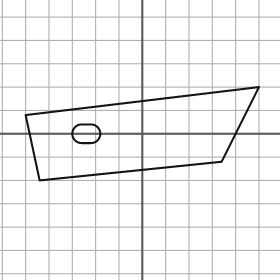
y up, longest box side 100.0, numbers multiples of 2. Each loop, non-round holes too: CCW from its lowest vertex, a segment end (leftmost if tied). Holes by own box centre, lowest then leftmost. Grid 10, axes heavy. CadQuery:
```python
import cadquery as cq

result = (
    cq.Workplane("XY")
    .moveTo(-44.0, -20.0)
    .lineTo(34.0, -12.0)
    .lineTo(50.0, 20.0)
    .lineTo(-50.0, 8.0)
    .close()
    .moveTo(-26.0, -4.0)
    .lineTo(-22.0, -4.0)
    .threePointArc((-18.0, 0.0), (-22.0, 4.0))
    .lineTo(-26.0, 4.0)
    .threePointArc((-30.0, 0.0), (-26.0, -4.0))
    .close()
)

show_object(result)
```